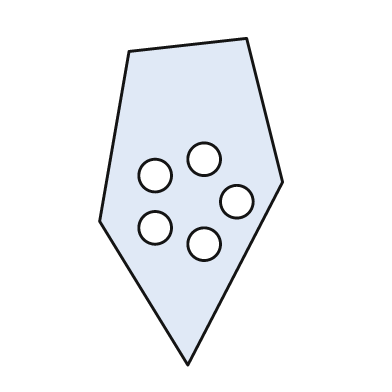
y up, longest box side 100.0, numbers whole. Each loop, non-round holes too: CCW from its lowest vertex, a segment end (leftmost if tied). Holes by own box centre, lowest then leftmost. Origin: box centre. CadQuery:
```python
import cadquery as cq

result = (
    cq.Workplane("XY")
    .moveTo(-1.0, -50.0)
    .lineTo(28.0, 6.0)
    .lineTo(17.0, 50.0)
    .lineTo(-19.0, 46.0)
    .lineTo(-28.0, -6.0)
    .close()
    .moveTo(4.0, -13.0)
    .circle(5.0)
    .moveTo(-11.0, -8.0)
    .circle(5.0)
    .moveTo(14.0, 0.0)
    .circle(5.0)
    .moveTo(-11.0, 8.0)
    .circle(5.0)
    .moveTo(4.0, 13.0)
    .circle(5.0)
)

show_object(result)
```